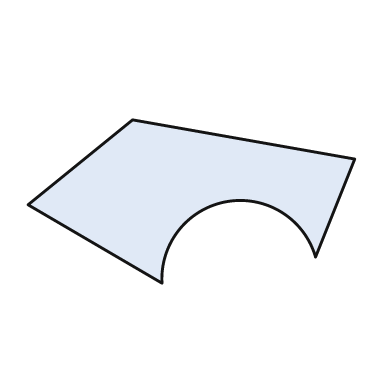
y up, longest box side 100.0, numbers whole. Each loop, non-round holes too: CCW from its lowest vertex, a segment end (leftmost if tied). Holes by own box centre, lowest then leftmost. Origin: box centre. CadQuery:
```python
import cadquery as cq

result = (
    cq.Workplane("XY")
    .moveTo(-9.0, -25.0)
    .threePointArc((11.0, 0.0), (38.0, -17.0))
    .lineTo(50.0, 13.0)
    .lineTo(-18.0, 25.0)
    .lineTo(-50.0, -1.0)
    .close()
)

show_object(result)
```